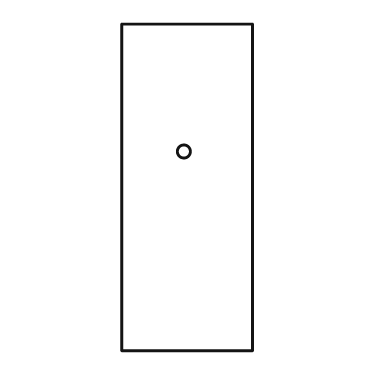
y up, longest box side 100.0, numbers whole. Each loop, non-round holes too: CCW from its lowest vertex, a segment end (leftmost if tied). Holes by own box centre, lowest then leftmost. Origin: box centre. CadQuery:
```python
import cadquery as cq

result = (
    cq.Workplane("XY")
    .moveTo(-20.0, -50.0)
    .lineTo(20.0, -50.0)
    .lineTo(20.0, 50.0)
    .lineTo(-20.0, 50.0)
    .close()
    .moveTo(-1.0, 11.0)
    .circle(2.0)
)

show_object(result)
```